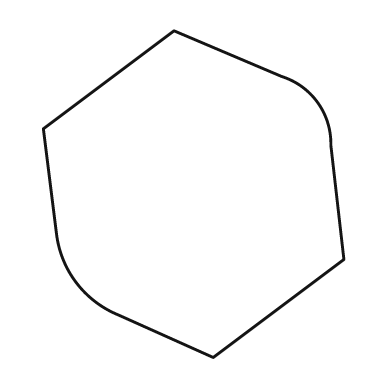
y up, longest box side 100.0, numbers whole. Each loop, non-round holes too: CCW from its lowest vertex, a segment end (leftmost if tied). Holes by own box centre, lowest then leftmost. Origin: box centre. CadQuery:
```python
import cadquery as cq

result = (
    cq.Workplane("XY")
    .moveTo(6.0, -50.0)
    .lineTo(46.0, -20.0)
    .lineTo(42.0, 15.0)
    .threePointArc((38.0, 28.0), (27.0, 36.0))
    .lineTo(-6.0, 50.0)
    .lineTo(-46.0, 20.0)
    .lineTo(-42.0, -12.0)
    .threePointArc((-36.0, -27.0), (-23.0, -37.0))
    .close()
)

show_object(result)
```